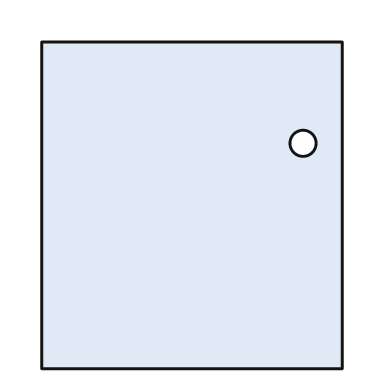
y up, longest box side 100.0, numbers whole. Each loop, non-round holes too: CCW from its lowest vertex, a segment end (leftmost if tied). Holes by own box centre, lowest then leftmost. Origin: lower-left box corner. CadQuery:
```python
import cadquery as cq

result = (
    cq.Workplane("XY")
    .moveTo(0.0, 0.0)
    .lineTo(92.0, 0.0)
    .lineTo(92.0, 100.0)
    .lineTo(0.0, 100.0)
    .close()
    .moveTo(80.0, 69.0)
    .circle(4.0)
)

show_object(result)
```